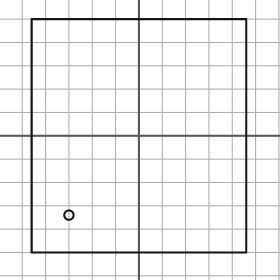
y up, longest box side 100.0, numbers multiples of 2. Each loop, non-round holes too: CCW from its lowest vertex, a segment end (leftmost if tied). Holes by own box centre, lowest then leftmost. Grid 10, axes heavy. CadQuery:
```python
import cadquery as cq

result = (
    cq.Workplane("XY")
    .moveTo(-46.0, -50.0)
    .lineTo(46.0, -50.0)
    .lineTo(46.0, 50.0)
    .lineTo(-46.0, 50.0)
    .close()
    .moveTo(-30.0, -34.0)
    .circle(2.0)
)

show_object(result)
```